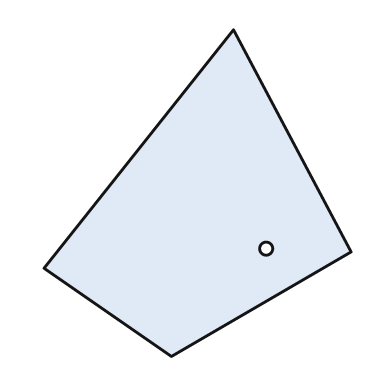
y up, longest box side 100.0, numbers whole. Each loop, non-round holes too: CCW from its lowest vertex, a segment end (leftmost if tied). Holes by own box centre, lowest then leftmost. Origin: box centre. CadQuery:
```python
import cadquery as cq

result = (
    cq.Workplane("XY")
    .moveTo(-8.0, -50.0)
    .lineTo(47.0, -18.0)
    .lineTo(11.0, 50.0)
    .lineTo(-47.0, -23.0)
    .close()
    .moveTo(21.0, -17.0)
    .circle(2.0)
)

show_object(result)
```